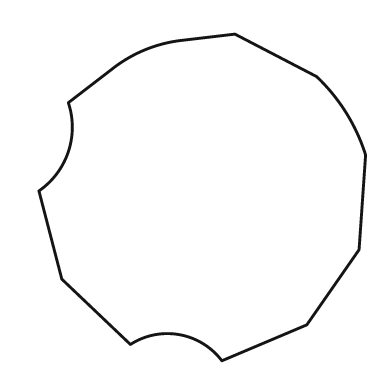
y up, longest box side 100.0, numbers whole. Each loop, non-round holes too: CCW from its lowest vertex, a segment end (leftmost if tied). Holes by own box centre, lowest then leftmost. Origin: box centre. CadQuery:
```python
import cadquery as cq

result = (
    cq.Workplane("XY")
    .moveTo(6.0, -50.0)
    .lineTo(32.0, -39.0)
    .lineTo(48.0, -16.0)
    .lineTo(50.0, 13.0)
    .threePointArc((44.0, 26.0), (35.0, 37.0))
    .lineTo(10.0, 50.0)
    .lineTo(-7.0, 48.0)
    .threePointArc((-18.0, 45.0), (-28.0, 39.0))
    .lineTo(-41.0, 29.0)
    .threePointArc((-41.0, 14.0), (-50.0, 2.0))
    .lineTo(-43.0, -25.0)
    .lineTo(-22.0, -45.0)
    .threePointArc((-7.0, -42.0), (6.0, -50.0))
    .close()
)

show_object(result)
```